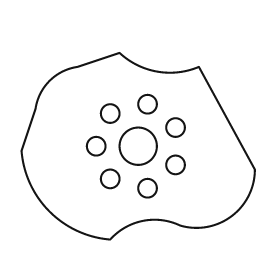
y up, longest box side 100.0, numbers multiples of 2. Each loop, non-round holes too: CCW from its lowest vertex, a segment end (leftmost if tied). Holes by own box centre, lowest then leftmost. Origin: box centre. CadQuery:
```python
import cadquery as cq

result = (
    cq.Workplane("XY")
    .moveTo(-12.0, -40.0)
    .threePointArc((2.0, -32.0), (18.0, -34.0))
    .threePointArc((40.0, -30.0), (50.0, -10.0))
    .lineTo(26.0, 34.0)
    .threePointArc((8.0, 32.0), (-8.0, 40.0))
    .lineTo(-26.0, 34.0)
    .threePointArc((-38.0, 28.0), (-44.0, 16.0))
    .lineTo(-50.0, -2.0)
    .threePointArc((-38.0, -28.0), (-12.0, -40.0))
    .close()
    .moveTo(4.0, -18.0)
    .circle(4.0)
    .moveTo(-12.0, -14.0)
    .circle(4.0)
    .moveTo(16.0, -8.0)
    .circle(4.0)
    .moveTo(-18.0, 0.0)
    .circle(4.0)
    .moveTo(0.0, 0.0)
    .circle(8.0)
    .moveTo(16.0, 8.0)
    .circle(4.0)
    .moveTo(-12.0, 14.0)
    .circle(4.0)
    .moveTo(4.0, 18.0)
    .circle(4.0)
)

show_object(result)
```